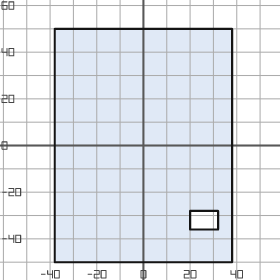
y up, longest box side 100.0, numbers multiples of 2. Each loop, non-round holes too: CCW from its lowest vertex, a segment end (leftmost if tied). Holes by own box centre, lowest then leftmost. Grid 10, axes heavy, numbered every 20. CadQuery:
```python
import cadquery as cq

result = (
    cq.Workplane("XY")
    .moveTo(-38.0, -50.0)
    .lineTo(38.0, -50.0)
    .lineTo(38.0, 50.0)
    .lineTo(-38.0, 50.0)
    .close()
    .moveTo(20.0, -36.0)
    .lineTo(32.0, -36.0)
    .lineTo(32.0, -28.0)
    .lineTo(20.0, -28.0)
    .close()
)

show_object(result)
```